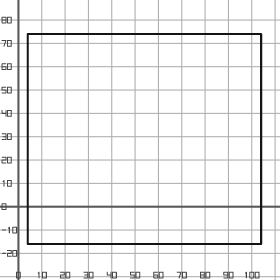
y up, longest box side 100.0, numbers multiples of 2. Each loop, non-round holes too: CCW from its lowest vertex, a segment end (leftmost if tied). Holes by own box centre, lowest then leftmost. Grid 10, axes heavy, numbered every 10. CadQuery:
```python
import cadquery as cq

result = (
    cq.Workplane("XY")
    .moveTo(4.0, -16.0)
    .lineTo(104.0, -16.0)
    .lineTo(104.0, 74.0)
    .lineTo(4.0, 74.0)
    .close()
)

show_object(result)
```